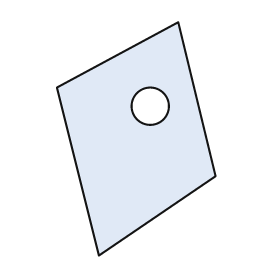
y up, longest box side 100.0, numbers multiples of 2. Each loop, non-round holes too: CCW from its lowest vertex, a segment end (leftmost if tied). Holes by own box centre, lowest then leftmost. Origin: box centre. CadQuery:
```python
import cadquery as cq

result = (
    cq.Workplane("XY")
    .moveTo(-16.0, -50.0)
    .lineTo(34.0, -16.0)
    .lineTo(18.0, 50.0)
    .lineTo(-34.0, 22.0)
    .close()
    .moveTo(6.0, 14.0)
    .circle(8.0)
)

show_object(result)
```